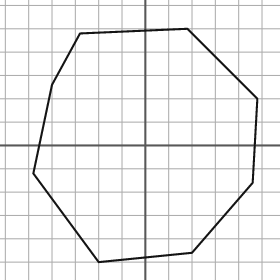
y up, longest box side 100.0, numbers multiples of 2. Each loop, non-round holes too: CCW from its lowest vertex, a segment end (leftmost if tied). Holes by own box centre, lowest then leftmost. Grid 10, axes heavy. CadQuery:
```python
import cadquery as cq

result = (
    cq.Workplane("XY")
    .moveTo(-20.0, -50.0)
    .lineTo(20.0, -46.0)
    .lineTo(46.0, -16.0)
    .lineTo(48.0, 20.0)
    .lineTo(18.0, 50.0)
    .lineTo(-28.0, 48.0)
    .lineTo(-40.0, 26.0)
    .lineTo(-48.0, -12.0)
    .close()
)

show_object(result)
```